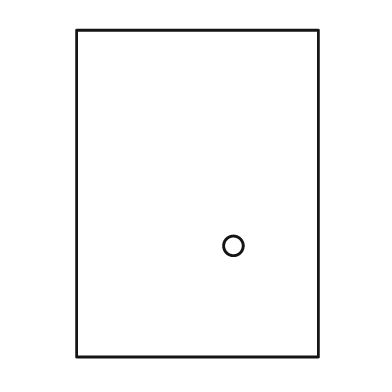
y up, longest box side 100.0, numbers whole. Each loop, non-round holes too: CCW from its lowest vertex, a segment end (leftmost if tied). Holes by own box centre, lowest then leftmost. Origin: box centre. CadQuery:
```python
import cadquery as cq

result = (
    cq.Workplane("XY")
    .moveTo(-37.0, -50.0)
    .lineTo(37.0, -50.0)
    .lineTo(37.0, 50.0)
    .lineTo(-37.0, 50.0)
    .close()
    .moveTo(11.0, -16.0)
    .circle(3.0)
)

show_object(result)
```